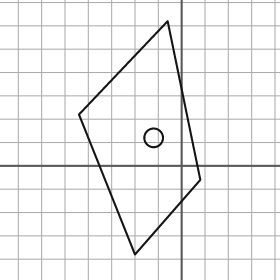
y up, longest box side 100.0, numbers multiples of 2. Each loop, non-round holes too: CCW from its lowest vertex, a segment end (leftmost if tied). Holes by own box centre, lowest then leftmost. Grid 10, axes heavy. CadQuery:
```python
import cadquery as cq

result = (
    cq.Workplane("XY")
    .moveTo(-20.0, -38.0)
    .lineTo(8.0, -6.0)
    .lineTo(-6.0, 62.0)
    .lineTo(-44.0, 22.0)
    .close()
    .moveTo(-12.0, 12.0)
    .circle(4.0)
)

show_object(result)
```